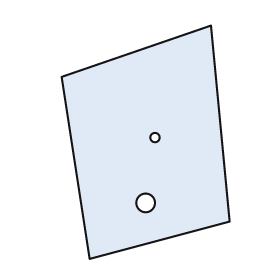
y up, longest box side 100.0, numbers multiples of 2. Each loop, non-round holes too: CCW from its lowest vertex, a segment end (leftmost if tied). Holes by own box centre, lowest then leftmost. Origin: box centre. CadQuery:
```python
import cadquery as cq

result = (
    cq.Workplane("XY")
    .moveTo(-24.0, -50.0)
    .lineTo(36.0, -34.0)
    .lineTo(28.0, 50.0)
    .lineTo(-36.0, 28.0)
    .close()
    .moveTo(0.0, -26.0)
    .circle(4.0)
    .moveTo(4.0, 2.0)
    .circle(2.0)
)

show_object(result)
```